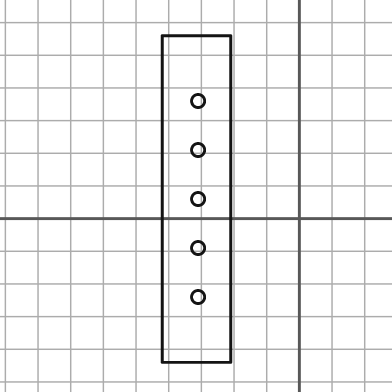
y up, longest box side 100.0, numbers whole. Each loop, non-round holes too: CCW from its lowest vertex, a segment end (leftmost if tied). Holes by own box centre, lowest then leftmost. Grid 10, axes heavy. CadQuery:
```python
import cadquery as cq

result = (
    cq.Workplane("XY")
    .moveTo(-42.0, -44.0)
    .lineTo(-21.0, -44.0)
    .lineTo(-21.0, 56.0)
    .lineTo(-42.0, 56.0)
    .close()
    .moveTo(-31.0, -24.0)
    .circle(2.0)
    .moveTo(-31.0, -9.0)
    .circle(2.0)
    .moveTo(-31.0, 6.0)
    .circle(2.0)
    .moveTo(-31.0, 21.0)
    .circle(2.0)
    .moveTo(-31.0, 36.0)
    .circle(2.0)
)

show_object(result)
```